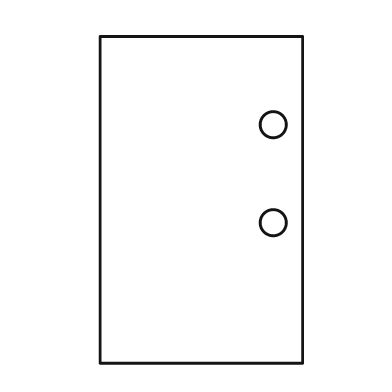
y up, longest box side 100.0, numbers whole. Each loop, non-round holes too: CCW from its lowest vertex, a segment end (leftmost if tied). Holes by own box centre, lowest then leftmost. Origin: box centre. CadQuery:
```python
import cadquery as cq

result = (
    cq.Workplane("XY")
    .moveTo(-31.0, -50.0)
    .lineTo(31.0, -50.0)
    .lineTo(31.0, 50.0)
    .lineTo(-31.0, 50.0)
    .close()
    .moveTo(22.0, -7.0)
    .circle(4.0)
    .moveTo(22.0, 23.0)
    .circle(4.0)
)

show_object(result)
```